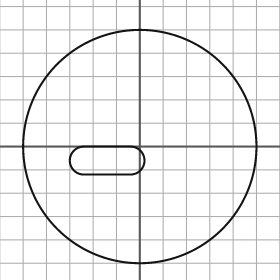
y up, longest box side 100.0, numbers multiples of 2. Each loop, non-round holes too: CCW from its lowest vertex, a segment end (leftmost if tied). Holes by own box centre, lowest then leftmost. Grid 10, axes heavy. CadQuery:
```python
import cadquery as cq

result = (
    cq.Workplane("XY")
    .moveTo(0.0, 0.0)
    .circle(50.0)
    .moveTo(-24.0, -12.0)
    .lineTo(-4.0, -12.0)
    .threePointArc((2.0, -6.0), (-4.0, 0.0))
    .lineTo(-24.0, 0.0)
    .threePointArc((-30.0, -6.0), (-24.0, -12.0))
    .close()
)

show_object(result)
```